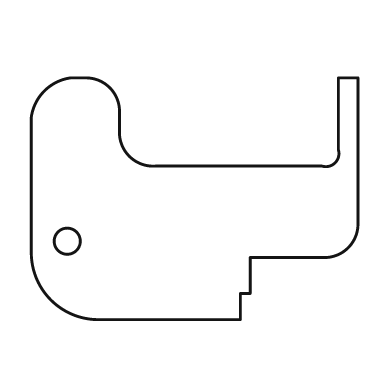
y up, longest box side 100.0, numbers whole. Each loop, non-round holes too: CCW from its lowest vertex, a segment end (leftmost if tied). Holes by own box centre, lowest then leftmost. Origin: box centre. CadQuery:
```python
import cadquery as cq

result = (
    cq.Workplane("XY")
    .moveTo(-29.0, -37.0)
    .lineTo(14.0, -37.0)
    .lineTo(14.0, -29.0)
    .lineTo(17.0, -29.0)
    .lineTo(17.0, -18.0)
    .lineTo(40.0, -18.0)
    .threePointArc((47.0, -15.0), (50.0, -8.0))
    .lineTo(50.0, 37.0)
    .lineTo(44.0, 37.0)
    .lineTo(44.0, 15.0)
    .threePointArc((43.0, 11.0), (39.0, 10.0))
    .lineTo(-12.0, 10.0)
    .threePointArc((-20.0, 13.0), (-23.0, 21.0))
    .lineTo(-23.0, 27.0)
    .threePointArc((-26.0, 34.0), (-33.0, 37.0))
    .lineTo(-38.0, 37.0)
    .threePointArc((-46.0, 33.0), (-50.0, 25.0))
    .lineTo(-50.0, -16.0)
    .threePointArc((-44.0, -31.0), (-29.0, -37.0))
    .close()
    .moveTo(-39.0, -13.0)
    .circle(4.0)
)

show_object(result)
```